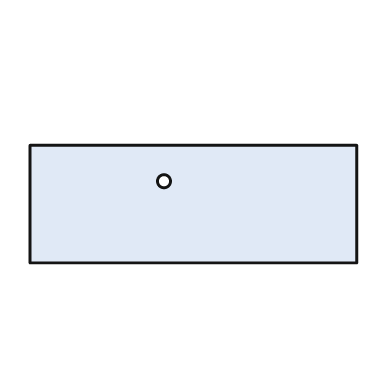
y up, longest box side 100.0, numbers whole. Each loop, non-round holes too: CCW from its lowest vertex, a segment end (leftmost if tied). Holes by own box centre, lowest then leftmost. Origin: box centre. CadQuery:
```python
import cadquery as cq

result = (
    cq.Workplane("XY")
    .moveTo(-50.0, -18.0)
    .lineTo(50.0, -18.0)
    .lineTo(50.0, 18.0)
    .lineTo(-50.0, 18.0)
    .close()
    .moveTo(-9.0, 7.0)
    .circle(2.0)
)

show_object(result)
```